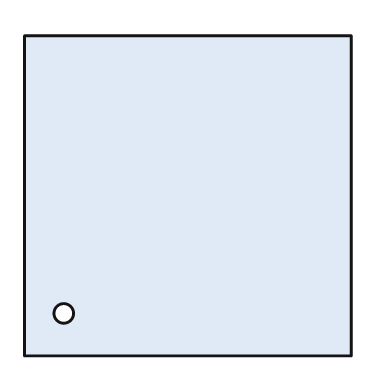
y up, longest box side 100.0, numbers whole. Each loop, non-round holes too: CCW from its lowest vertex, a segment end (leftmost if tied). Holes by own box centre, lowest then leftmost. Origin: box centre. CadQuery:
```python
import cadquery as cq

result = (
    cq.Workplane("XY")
    .moveTo(-50.0, -49.0)
    .lineTo(50.0, -49.0)
    .lineTo(50.0, 49.0)
    .lineTo(-50.0, 49.0)
    .close()
    .moveTo(-38.0, -36.0)
    .circle(3.0)
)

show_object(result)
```